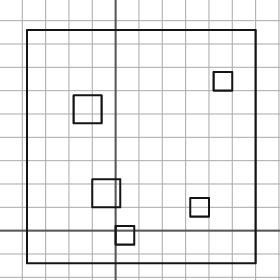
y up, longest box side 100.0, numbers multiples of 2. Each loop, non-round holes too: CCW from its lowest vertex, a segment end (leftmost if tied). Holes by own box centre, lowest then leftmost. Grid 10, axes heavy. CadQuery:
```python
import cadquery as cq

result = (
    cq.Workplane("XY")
    .moveTo(-38.0, -14.0)
    .lineTo(60.0, -14.0)
    .lineTo(60.0, 86.0)
    .lineTo(-38.0, 86.0)
    .close()
    .moveTo(0.0, -6.0)
    .lineTo(8.0, -6.0)
    .lineTo(8.0, 2.0)
    .lineTo(0.0, 2.0)
    .close()
    .moveTo(32.0, 6.0)
    .lineTo(40.0, 6.0)
    .lineTo(40.0, 14.0)
    .lineTo(32.0, 14.0)
    .close()
    .moveTo(-10.0, 10.0)
    .lineTo(2.0, 10.0)
    .lineTo(2.0, 22.0)
    .lineTo(-10.0, 22.0)
    .close()
    .moveTo(-18.0, 46.0)
    .lineTo(-6.0, 46.0)
    .lineTo(-6.0, 58.0)
    .lineTo(-18.0, 58.0)
    .close()
    .moveTo(42.0, 60.0)
    .lineTo(50.0, 60.0)
    .lineTo(50.0, 68.0)
    .lineTo(42.0, 68.0)
    .close()
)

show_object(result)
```